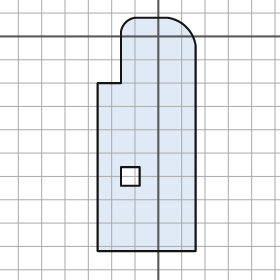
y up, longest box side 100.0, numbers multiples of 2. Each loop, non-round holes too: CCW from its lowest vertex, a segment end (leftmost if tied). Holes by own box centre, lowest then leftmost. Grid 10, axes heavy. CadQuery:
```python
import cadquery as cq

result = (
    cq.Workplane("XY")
    .moveTo(-26.0, -92.0)
    .lineTo(16.0, -92.0)
    .lineTo(16.0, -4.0)
    .threePointArc((12.0, 4.0), (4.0, 8.0))
    .lineTo(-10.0, 8.0)
    .threePointArc((-14.0, 6.0), (-16.0, 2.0))
    .lineTo(-16.0, -20.0)
    .lineTo(-26.0, -20.0)
    .close()
    .moveTo(-16.0, -64.0)
    .lineTo(-8.0, -64.0)
    .lineTo(-8.0, -56.0)
    .lineTo(-16.0, -56.0)
    .close()
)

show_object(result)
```